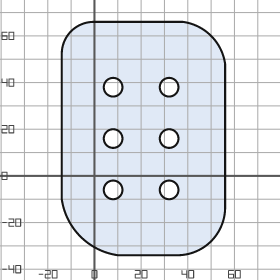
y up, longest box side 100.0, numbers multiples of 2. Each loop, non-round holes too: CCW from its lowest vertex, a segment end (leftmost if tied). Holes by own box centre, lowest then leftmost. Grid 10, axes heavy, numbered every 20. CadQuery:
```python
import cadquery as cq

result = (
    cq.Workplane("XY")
    .moveTo(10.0, -34.0)
    .lineTo(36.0, -34.0)
    .threePointArc((50.0, -28.0), (56.0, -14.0))
    .lineTo(56.0, 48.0)
    .threePointArc((50.0, 60.0), (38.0, 66.0))
    .lineTo(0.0, 66.0)
    .threePointArc((-10.0, 62.0), (-14.0, 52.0))
    .lineTo(-14.0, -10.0)
    .threePointArc((-6.0, -26.0), (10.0, -34.0))
    .close()
    .moveTo(8.0, -6.0)
    .circle(4.0)
    .moveTo(32.0, -6.0)
    .circle(4.0)
    .moveTo(8.0, 16.0)
    .circle(4.0)
    .moveTo(32.0, 16.0)
    .circle(4.0)
    .moveTo(8.0, 38.0)
    .circle(4.0)
    .moveTo(32.0, 38.0)
    .circle(4.0)
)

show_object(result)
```